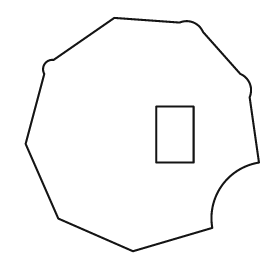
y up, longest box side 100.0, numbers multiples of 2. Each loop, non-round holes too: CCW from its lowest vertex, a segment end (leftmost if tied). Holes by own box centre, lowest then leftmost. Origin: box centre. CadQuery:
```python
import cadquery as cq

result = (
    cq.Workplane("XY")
    .moveTo(-4.0, -50.0)
    .lineTo(30.0, -40.0)
    .threePointArc((34.0, -22.0), (50.0, -12.0))
    .lineTo(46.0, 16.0)
    .threePointArc((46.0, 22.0), (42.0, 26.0))
    .lineTo(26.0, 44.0)
    .threePointArc((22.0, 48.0), (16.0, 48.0))
    .lineTo(-12.0, 50.0)
    .lineTo(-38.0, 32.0)
    .threePointArc((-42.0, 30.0), (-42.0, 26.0))
    .lineTo(-50.0, -4.0)
    .lineTo(-36.0, -36.0)
    .close()
    .moveTo(6.0, -12.0)
    .lineTo(22.0, -12.0)
    .lineTo(22.0, 12.0)
    .lineTo(6.0, 12.0)
    .close()
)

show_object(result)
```